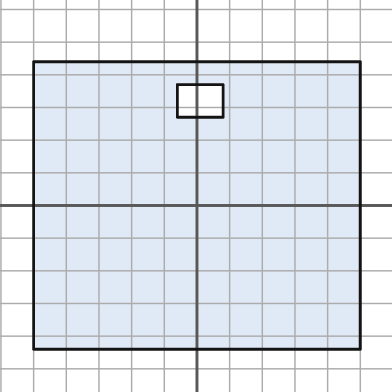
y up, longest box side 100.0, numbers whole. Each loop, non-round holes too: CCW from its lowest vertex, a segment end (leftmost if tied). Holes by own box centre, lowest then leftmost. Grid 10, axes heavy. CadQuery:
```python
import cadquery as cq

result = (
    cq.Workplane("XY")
    .moveTo(-50.0, -44.0)
    .lineTo(50.0, -44.0)
    .lineTo(50.0, 44.0)
    .lineTo(-50.0, 44.0)
    .close()
    .moveTo(-6.0, 27.0)
    .lineTo(8.0, 27.0)
    .lineTo(8.0, 37.0)
    .lineTo(-6.0, 37.0)
    .close()
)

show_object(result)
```